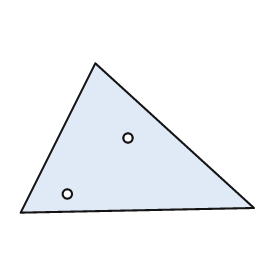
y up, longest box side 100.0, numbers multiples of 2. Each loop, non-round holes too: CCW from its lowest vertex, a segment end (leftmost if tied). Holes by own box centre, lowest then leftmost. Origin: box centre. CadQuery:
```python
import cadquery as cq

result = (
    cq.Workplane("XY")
    .moveTo(-50.0, -32.0)
    .lineTo(50.0, -30.0)
    .lineTo(-18.0, 32.0)
    .close()
    .moveTo(-30.0, -24.0)
    .circle(2.0)
    .moveTo(-4.0, 0.0)
    .circle(2.0)
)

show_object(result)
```